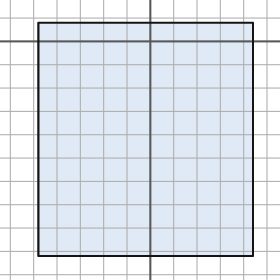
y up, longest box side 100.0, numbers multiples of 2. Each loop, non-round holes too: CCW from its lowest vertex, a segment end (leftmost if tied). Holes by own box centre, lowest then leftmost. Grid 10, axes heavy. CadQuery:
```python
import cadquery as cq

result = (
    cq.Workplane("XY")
    .moveTo(-48.0, -92.0)
    .lineTo(44.0, -92.0)
    .lineTo(44.0, 8.0)
    .lineTo(-48.0, 8.0)
    .close()
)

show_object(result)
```